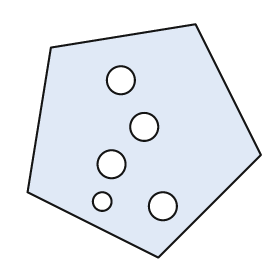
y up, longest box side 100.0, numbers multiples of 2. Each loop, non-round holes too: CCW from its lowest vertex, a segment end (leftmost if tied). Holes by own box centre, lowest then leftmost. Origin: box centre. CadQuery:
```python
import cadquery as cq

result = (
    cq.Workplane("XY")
    .moveTo(6.0, -50.0)
    .lineTo(50.0, -6.0)
    .lineTo(22.0, 50.0)
    .lineTo(-40.0, 40.0)
    .lineTo(-50.0, -22.0)
    .close()
    .moveTo(8.0, -28.0)
    .circle(6.0)
    .moveTo(-18.0, -26.0)
    .circle(4.0)
    .moveTo(-14.0, -10.0)
    .circle(6.0)
    .moveTo(0.0, 6.0)
    .circle(6.0)
    .moveTo(-10.0, 26.0)
    .circle(6.0)
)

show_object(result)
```